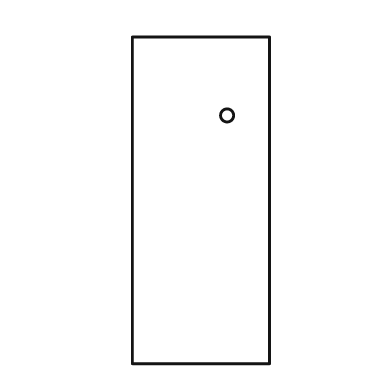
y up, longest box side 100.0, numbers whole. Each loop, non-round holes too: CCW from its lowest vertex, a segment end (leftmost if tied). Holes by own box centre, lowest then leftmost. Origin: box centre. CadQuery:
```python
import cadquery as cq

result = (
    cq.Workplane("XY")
    .moveTo(-21.0, -50.0)
    .lineTo(21.0, -50.0)
    .lineTo(21.0, 50.0)
    .lineTo(-21.0, 50.0)
    .close()
    .moveTo(8.0, 26.0)
    .circle(2.0)
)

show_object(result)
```